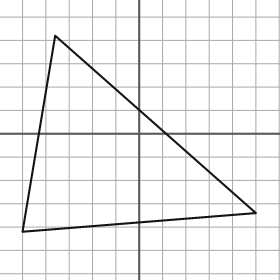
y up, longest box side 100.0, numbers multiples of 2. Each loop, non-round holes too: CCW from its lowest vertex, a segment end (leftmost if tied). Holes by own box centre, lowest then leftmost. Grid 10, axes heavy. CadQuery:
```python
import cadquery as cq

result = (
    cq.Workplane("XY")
    .moveTo(-50.0, -42.0)
    .lineTo(50.0, -34.0)
    .lineTo(-36.0, 42.0)
    .close()
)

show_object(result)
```